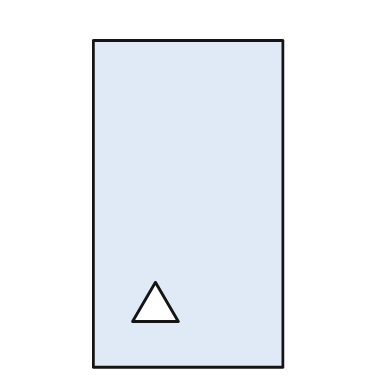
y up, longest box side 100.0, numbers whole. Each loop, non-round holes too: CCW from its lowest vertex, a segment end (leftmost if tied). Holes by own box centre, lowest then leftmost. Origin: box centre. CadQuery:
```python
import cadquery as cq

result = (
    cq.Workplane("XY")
    .moveTo(-29.0, -50.0)
    .lineTo(29.0, -50.0)
    .lineTo(29.0, 50.0)
    .lineTo(-29.0, 50.0)
    .close()
    .moveTo(-17.0, -36.0)
    .lineTo(-3.0, -36.0)
    .lineTo(-10.0, -24.0)
    .close()
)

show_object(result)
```